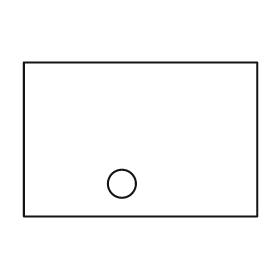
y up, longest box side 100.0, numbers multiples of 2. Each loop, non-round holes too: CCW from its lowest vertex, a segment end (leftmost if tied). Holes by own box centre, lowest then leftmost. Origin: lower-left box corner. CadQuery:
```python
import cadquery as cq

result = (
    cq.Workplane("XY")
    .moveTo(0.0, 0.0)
    .lineTo(100.0, 0.0)
    .lineTo(100.0, 66.0)
    .lineTo(0.0, 66.0)
    .close()
    .moveTo(42.0, 14.0)
    .circle(6.0)
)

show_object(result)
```